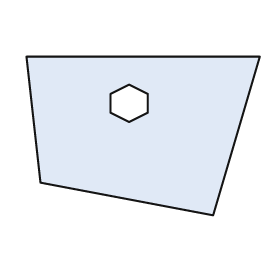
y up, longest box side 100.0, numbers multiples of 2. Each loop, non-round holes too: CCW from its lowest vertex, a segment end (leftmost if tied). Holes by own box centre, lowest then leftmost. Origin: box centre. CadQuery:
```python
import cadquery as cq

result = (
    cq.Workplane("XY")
    .moveTo(30.0, -34.0)
    .lineTo(50.0, 34.0)
    .lineTo(-50.0, 34.0)
    .lineTo(-44.0, -20.0)
    .close()
    .moveTo(-6.0, 6.0)
    .lineTo(2.0, 10.0)
    .lineTo(2.0, 18.0)
    .lineTo(-6.0, 22.0)
    .lineTo(-14.0, 18.0)
    .lineTo(-14.0, 10.0)
    .close()
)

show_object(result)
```